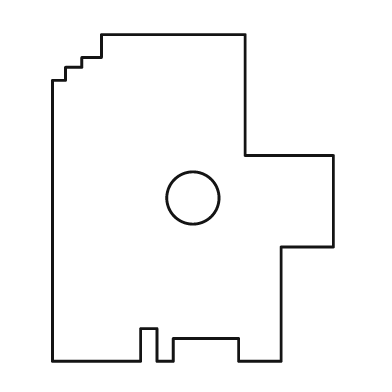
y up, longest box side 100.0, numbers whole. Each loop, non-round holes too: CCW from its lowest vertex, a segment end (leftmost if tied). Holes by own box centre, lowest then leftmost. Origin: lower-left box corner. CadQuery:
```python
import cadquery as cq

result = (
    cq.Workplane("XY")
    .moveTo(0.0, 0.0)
    .lineTo(27.0, 0.0)
    .lineTo(27.0, 10.0)
    .lineTo(32.0, 10.0)
    .lineTo(32.0, 0.0)
    .lineTo(37.0, 0.0)
    .lineTo(37.0, 7.0)
    .lineTo(57.0, 7.0)
    .lineTo(57.0, 0.0)
    .lineTo(70.0, 0.0)
    .lineTo(70.0, 35.0)
    .lineTo(86.0, 35.0)
    .lineTo(86.0, 63.0)
    .lineTo(59.0, 63.0)
    .lineTo(59.0, 100.0)
    .lineTo(15.0, 100.0)
    .lineTo(15.0, 93.0)
    .lineTo(9.0, 93.0)
    .lineTo(9.0, 90.0)
    .lineTo(4.0, 90.0)
    .lineTo(4.0, 86.0)
    .lineTo(0.0, 86.0)
    .close()
    .moveTo(43.0, 50.0)
    .circle(8.0)
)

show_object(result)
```